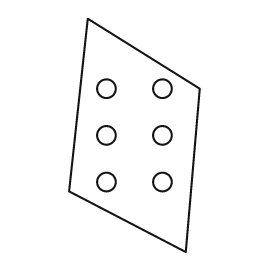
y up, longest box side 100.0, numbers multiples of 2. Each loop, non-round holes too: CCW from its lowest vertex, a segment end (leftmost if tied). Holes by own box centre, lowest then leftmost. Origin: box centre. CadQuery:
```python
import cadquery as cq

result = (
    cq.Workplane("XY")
    .moveTo(22.0, -50.0)
    .lineTo(28.0, 20.0)
    .lineTo(-20.0, 50.0)
    .lineTo(-28.0, -24.0)
    .close()
    .moveTo(-12.0, -20.0)
    .circle(4.0)
    .moveTo(12.0, -20.0)
    .circle(4.0)
    .moveTo(-12.0, 0.0)
    .circle(4.0)
    .moveTo(12.0, 0.0)
    .circle(4.0)
    .moveTo(-12.0, 20.0)
    .circle(4.0)
    .moveTo(12.0, 20.0)
    .circle(4.0)
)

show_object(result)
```